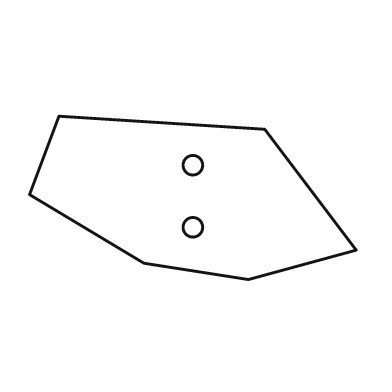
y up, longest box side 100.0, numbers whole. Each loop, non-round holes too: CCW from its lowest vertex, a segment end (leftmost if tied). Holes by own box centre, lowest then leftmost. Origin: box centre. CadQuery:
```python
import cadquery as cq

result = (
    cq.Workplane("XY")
    .moveTo(17.0, -25.0)
    .lineTo(50.0, -16.0)
    .lineTo(22.0, 21.0)
    .lineTo(-41.0, 25.0)
    .lineTo(-50.0, 1.0)
    .lineTo(-15.0, -20.0)
    .close()
    .moveTo(0.0, -9.0)
    .circle(3.0)
    .moveTo(0.0, 10.0)
    .circle(3.0)
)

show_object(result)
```